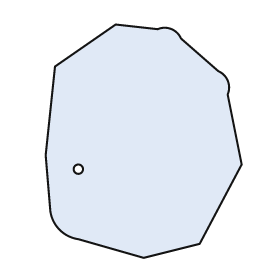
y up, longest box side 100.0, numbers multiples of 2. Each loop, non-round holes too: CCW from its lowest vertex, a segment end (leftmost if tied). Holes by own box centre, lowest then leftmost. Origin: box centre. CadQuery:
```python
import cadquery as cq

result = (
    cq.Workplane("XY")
    .moveTo(0.0, -50.0)
    .lineTo(24.0, -44.0)
    .lineTo(42.0, -10.0)
    .lineTo(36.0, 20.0)
    .threePointArc((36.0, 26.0), (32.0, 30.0))
    .lineTo(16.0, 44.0)
    .threePointArc((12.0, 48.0), (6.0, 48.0))
    .lineTo(-12.0, 50.0)
    .lineTo(-38.0, 32.0)
    .lineTo(-42.0, -6.0)
    .lineTo(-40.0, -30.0)
    .threePointArc((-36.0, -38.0), (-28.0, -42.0))
    .close()
    .moveTo(-28.0, -12.0)
    .circle(2.0)
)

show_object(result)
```